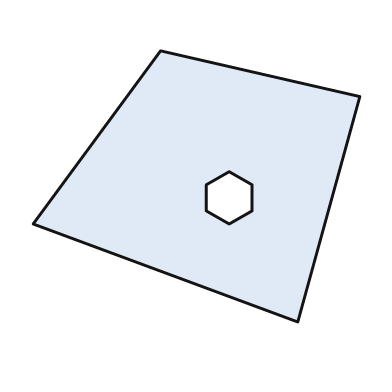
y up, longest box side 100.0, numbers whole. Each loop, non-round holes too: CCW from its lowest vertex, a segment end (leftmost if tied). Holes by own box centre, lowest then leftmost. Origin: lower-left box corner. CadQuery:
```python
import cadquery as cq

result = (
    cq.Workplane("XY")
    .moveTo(81.0, 0.0)
    .lineTo(100.0, 69.0)
    .lineTo(39.0, 83.0)
    .lineTo(0.0, 30.0)
    .close()
    .moveTo(60.0, 30.0)
    .lineTo(67.0, 34.0)
    .lineTo(67.0, 42.0)
    .lineTo(60.0, 46.0)
    .lineTo(53.0, 42.0)
    .lineTo(53.0, 34.0)
    .close()
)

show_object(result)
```